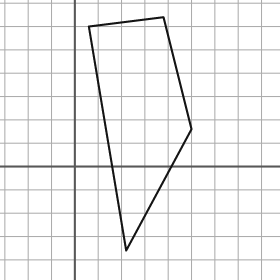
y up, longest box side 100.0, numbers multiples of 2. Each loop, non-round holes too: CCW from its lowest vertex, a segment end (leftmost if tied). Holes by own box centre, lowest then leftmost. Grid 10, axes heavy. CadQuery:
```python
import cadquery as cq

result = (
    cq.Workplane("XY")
    .moveTo(22.0, -36.0)
    .lineTo(50.0, 16.0)
    .lineTo(38.0, 64.0)
    .lineTo(6.0, 60.0)
    .close()
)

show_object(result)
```